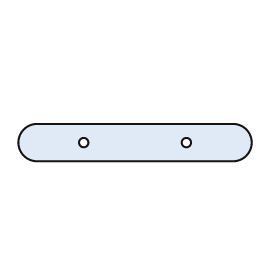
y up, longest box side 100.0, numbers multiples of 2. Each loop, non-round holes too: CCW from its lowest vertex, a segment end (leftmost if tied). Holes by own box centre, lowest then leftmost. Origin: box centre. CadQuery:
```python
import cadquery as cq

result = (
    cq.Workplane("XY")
    .moveTo(-42.0, -8.0)
    .lineTo(42.0, -8.0)
    .threePointArc((50.0, 0.0), (42.0, 8.0))
    .lineTo(-42.0, 8.0)
    .threePointArc((-50.0, 0.0), (-42.0, -8.0))
    .close()
    .moveTo(-22.0, 0.0)
    .circle(2.0)
    .moveTo(22.0, 0.0)
    .circle(2.0)
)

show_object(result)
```